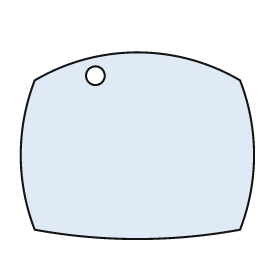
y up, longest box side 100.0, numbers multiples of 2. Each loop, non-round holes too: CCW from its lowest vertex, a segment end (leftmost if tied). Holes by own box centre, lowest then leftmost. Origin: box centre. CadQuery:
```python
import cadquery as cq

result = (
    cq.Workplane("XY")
    .moveTo(-44.0, -36.0)
    .threePointArc((0.0, -40.0), (44.0, -36.0))
    .threePointArc((50.0, -4.0), (44.0, 28.0))
    .threePointArc((0.0, 40.0), (-44.0, 28.0))
    .threePointArc((-50.0, -4.0), (-44.0, -36.0))
    .close()
    .moveTo(-18.0, 30.0)
    .circle(4.0)
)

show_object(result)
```